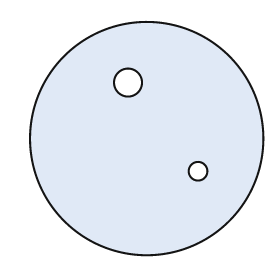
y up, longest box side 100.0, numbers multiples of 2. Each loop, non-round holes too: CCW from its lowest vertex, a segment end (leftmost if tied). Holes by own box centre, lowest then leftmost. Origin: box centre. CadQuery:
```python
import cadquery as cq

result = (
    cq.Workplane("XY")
    .moveTo(0.0, 0.0)
    .circle(50.0)
    .moveTo(22.0, -14.0)
    .circle(4.0)
    .moveTo(-8.0, 24.0)
    .circle(6.0)
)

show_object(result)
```